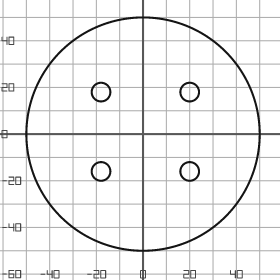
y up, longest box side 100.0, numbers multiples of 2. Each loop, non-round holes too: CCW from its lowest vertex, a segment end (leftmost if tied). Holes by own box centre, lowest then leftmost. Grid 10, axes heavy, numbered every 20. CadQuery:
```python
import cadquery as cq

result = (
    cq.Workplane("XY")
    .moveTo(0.0, 0.0)
    .circle(50.0)
    .moveTo(-18.0, -16.0)
    .circle(4.0)
    .moveTo(20.0, -16.0)
    .circle(4.0)
    .moveTo(-18.0, 18.0)
    .circle(4.0)
    .moveTo(20.0, 18.0)
    .circle(4.0)
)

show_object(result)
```